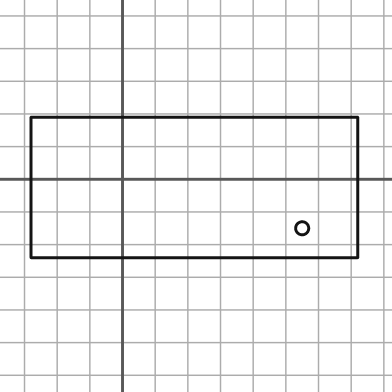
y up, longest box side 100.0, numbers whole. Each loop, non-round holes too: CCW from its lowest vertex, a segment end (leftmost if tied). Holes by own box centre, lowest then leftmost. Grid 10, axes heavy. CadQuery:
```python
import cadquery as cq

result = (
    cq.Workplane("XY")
    .moveTo(-28.0, -24.0)
    .lineTo(72.0, -24.0)
    .lineTo(72.0, 19.0)
    .lineTo(-28.0, 19.0)
    .close()
    .moveTo(55.0, -15.0)
    .circle(2.0)
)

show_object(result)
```